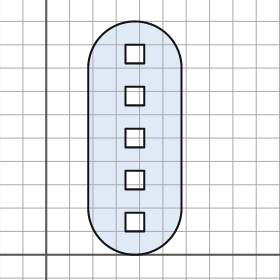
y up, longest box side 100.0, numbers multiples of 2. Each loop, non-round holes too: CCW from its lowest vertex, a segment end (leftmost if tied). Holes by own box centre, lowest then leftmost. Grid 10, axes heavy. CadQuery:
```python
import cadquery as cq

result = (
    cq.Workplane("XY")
    .moveTo(18.0, 20.0)
    .threePointArc((38.0, 0.0), (58.0, 20.0))
    .lineTo(58.0, 80.0)
    .threePointArc((38.0, 100.0), (18.0, 80.0))
    .close()
    .moveTo(34.0, 10.0)
    .lineTo(42.0, 10.0)
    .lineTo(42.0, 18.0)
    .lineTo(34.0, 18.0)
    .close()
    .moveTo(34.0, 28.0)
    .lineTo(42.0, 28.0)
    .lineTo(42.0, 36.0)
    .lineTo(34.0, 36.0)
    .close()
    .moveTo(34.0, 46.0)
    .lineTo(42.0, 46.0)
    .lineTo(42.0, 54.0)
    .lineTo(34.0, 54.0)
    .close()
    .moveTo(34.0, 64.0)
    .lineTo(42.0, 64.0)
    .lineTo(42.0, 72.0)
    .lineTo(34.0, 72.0)
    .close()
    .moveTo(34.0, 82.0)
    .lineTo(42.0, 82.0)
    .lineTo(42.0, 90.0)
    .lineTo(34.0, 90.0)
    .close()
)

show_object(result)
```